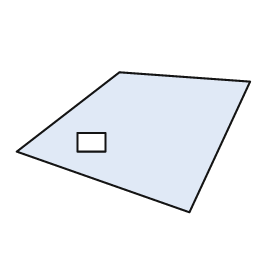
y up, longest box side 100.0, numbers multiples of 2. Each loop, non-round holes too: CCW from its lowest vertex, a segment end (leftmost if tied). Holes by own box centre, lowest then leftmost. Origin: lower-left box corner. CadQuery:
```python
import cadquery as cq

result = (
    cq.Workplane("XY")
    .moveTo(74.0, 0.0)
    .lineTo(100.0, 56.0)
    .lineTo(44.0, 60.0)
    .lineTo(0.0, 26.0)
    .close()
    .moveTo(26.0, 26.0)
    .lineTo(38.0, 26.0)
    .lineTo(38.0, 34.0)
    .lineTo(26.0, 34.0)
    .close()
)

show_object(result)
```